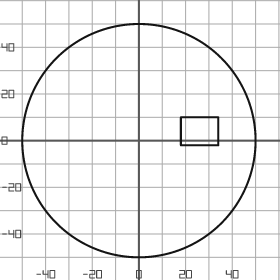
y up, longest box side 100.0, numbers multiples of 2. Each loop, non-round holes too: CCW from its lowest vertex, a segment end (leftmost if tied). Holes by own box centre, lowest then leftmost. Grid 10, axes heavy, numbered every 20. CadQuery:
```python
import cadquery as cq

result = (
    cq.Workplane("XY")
    .moveTo(0.0, 0.0)
    .circle(50.0)
    .moveTo(18.0, -2.0)
    .lineTo(34.0, -2.0)
    .lineTo(34.0, 10.0)
    .lineTo(18.0, 10.0)
    .close()
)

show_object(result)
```